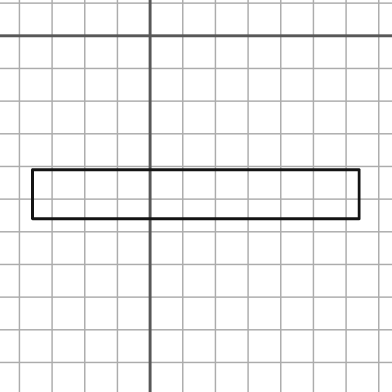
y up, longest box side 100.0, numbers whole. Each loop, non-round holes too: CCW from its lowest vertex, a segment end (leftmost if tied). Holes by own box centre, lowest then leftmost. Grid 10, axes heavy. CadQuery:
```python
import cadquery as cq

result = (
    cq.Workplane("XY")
    .moveTo(-36.0, -56.0)
    .lineTo(64.0, -56.0)
    .lineTo(64.0, -41.0)
    .lineTo(-36.0, -41.0)
    .close()
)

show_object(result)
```